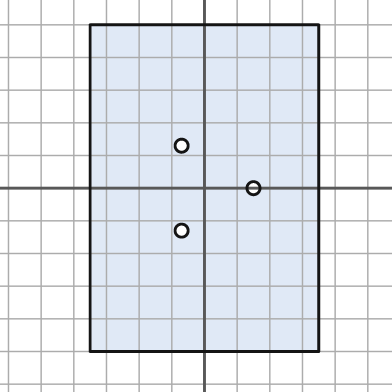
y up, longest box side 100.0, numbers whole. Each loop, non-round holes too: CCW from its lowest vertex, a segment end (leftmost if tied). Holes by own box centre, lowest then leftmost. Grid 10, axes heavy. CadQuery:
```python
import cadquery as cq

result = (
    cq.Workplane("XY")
    .moveTo(-35.0, -50.0)
    .lineTo(35.0, -50.0)
    .lineTo(35.0, 50.0)
    .lineTo(-35.0, 50.0)
    .close()
    .moveTo(-7.0, -13.0)
    .circle(2.0)
    .moveTo(15.0, 0.0)
    .circle(2.0)
    .moveTo(-7.0, 13.0)
    .circle(2.0)
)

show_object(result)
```